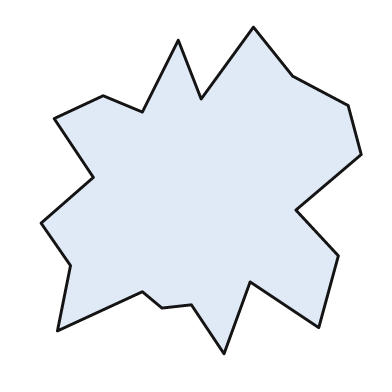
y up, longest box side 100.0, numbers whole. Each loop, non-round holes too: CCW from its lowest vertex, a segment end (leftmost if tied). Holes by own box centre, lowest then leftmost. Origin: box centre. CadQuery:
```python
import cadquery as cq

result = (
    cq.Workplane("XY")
    .moveTo(7.0, -50.0)
    .lineTo(15.0, -28.0)
    .lineTo(36.0, -42.0)
    .lineTo(42.0, -20.0)
    .lineTo(29.0, -6.0)
    .lineTo(49.0, 11.0)
    .lineTo(45.0, 26.0)
    .lineTo(28.0, 35.0)
    .lineTo(16.0, 50.0)
    .lineTo(0.0, 28.0)
    .lineTo(-7.0, 46.0)
    .lineTo(-18.0, 24.0)
    .lineTo(-30.0, 29.0)
    .lineTo(-45.0, 22.0)
    .lineTo(-33.0, 4.0)
    .lineTo(-49.0, -10.0)
    .lineTo(-40.0, -23.0)
    .lineTo(-44.0, -43.0)
    .lineTo(-18.0, -31.0)
    .lineTo(-12.0, -36.0)
    .lineTo(-3.0, -35.0)
    .close()
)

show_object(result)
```